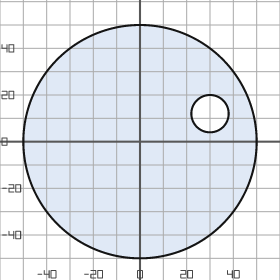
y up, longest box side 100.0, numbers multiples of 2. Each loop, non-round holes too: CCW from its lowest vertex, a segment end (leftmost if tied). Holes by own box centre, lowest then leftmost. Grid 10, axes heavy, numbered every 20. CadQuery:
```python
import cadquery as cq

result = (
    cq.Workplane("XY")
    .moveTo(0.0, 0.0)
    .circle(50.0)
    .moveTo(30.0, 12.0)
    .circle(8.0)
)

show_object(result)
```